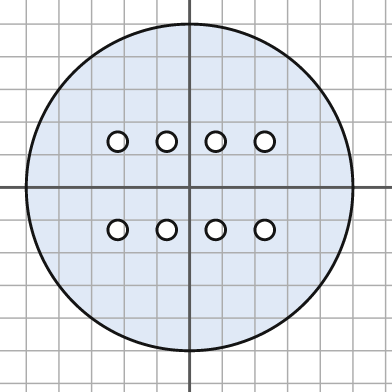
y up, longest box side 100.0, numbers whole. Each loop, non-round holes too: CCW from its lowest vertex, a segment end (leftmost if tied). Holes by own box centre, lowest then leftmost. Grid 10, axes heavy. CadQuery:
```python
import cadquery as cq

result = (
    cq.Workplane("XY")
    .moveTo(0.0, 0.0)
    .circle(50.0)
    .moveTo(-22.0, -13.0)
    .circle(3.0)
    .moveTo(-7.0, -13.0)
    .circle(3.0)
    .moveTo(8.0, -13.0)
    .circle(3.0)
    .moveTo(23.0, -13.0)
    .circle(3.0)
    .moveTo(-22.0, 14.0)
    .circle(3.0)
    .moveTo(-7.0, 14.0)
    .circle(3.0)
    .moveTo(8.0, 14.0)
    .circle(3.0)
    .moveTo(23.0, 14.0)
    .circle(3.0)
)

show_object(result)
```